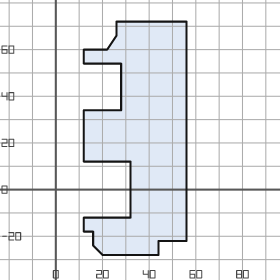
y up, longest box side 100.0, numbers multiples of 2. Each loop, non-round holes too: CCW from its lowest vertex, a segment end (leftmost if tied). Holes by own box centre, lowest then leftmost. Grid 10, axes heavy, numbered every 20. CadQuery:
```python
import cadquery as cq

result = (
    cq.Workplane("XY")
    .moveTo(20.0, -28.0)
    .lineTo(44.0, -28.0)
    .lineTo(44.0, -22.0)
    .lineTo(56.0, -22.0)
    .lineTo(56.0, 72.0)
    .lineTo(26.0, 72.0)
    .lineTo(26.0, 66.0)
    .lineTo(22.0, 60.0)
    .lineTo(12.0, 60.0)
    .lineTo(12.0, 54.0)
    .lineTo(28.0, 54.0)
    .lineTo(28.0, 34.0)
    .lineTo(12.0, 34.0)
    .lineTo(12.0, 12.0)
    .lineTo(32.0, 12.0)
    .lineTo(32.0, -12.0)
    .lineTo(12.0, -12.0)
    .lineTo(12.0, -18.0)
    .lineTo(16.0, -18.0)
    .lineTo(16.0, -24.0)
    .close()
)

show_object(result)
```